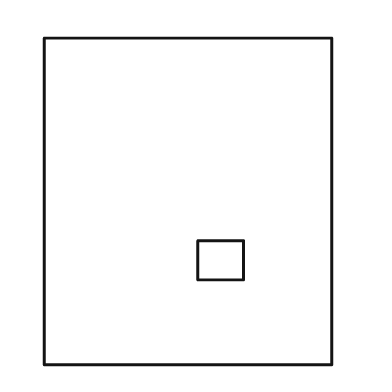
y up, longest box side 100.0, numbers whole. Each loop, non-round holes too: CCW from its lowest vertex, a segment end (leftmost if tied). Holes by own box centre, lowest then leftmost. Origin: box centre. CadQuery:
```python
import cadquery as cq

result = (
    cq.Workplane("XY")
    .moveTo(-44.0, -50.0)
    .lineTo(44.0, -50.0)
    .lineTo(44.0, 50.0)
    .lineTo(-44.0, 50.0)
    .close()
    .moveTo(3.0, -24.0)
    .lineTo(17.0, -24.0)
    .lineTo(17.0, -12.0)
    .lineTo(3.0, -12.0)
    .close()
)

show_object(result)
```